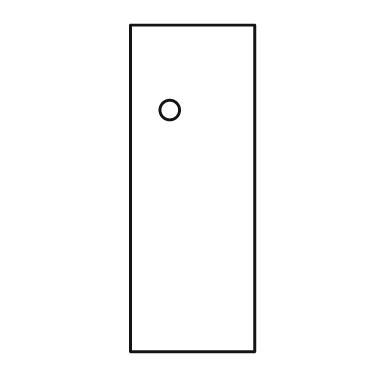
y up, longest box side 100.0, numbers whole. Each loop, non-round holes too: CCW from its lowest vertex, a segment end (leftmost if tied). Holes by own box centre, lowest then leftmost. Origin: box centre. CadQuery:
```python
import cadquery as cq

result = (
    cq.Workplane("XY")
    .moveTo(-19.0, -50.0)
    .lineTo(19.0, -50.0)
    .lineTo(19.0, 50.0)
    .lineTo(-19.0, 50.0)
    .close()
    .moveTo(-7.0, 24.0)
    .circle(3.0)
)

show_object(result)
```